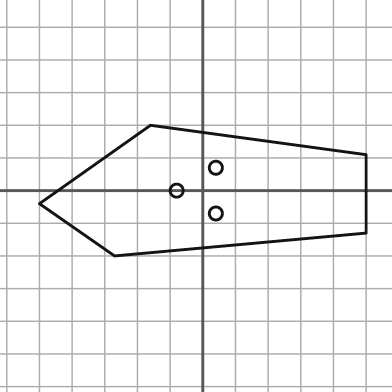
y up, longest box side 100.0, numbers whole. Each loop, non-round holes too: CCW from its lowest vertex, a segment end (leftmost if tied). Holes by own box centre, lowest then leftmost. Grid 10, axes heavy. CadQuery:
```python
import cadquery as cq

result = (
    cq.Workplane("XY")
    .moveTo(-27.0, -20.0)
    .lineTo(50.0, -13.0)
    .lineTo(50.0, 11.0)
    .lineTo(-16.0, 20.0)
    .lineTo(-50.0, -4.0)
    .close()
    .moveTo(4.0, -7.0)
    .circle(2.0)
    .moveTo(-8.0, 0.0)
    .circle(2.0)
    .moveTo(4.0, 7.0)
    .circle(2.0)
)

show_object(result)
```